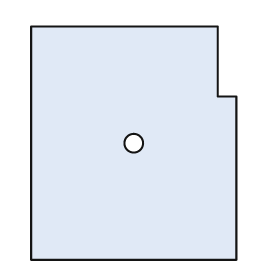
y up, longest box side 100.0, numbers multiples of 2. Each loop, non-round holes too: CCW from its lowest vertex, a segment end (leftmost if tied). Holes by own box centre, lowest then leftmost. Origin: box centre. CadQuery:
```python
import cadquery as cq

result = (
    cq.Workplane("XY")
    .moveTo(-44.0, -50.0)
    .lineTo(44.0, -50.0)
    .lineTo(44.0, 20.0)
    .lineTo(36.0, 20.0)
    .lineTo(36.0, 50.0)
    .lineTo(-44.0, 50.0)
    .close()
    .moveTo(0.0, 0.0)
    .circle(4.0)
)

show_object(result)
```